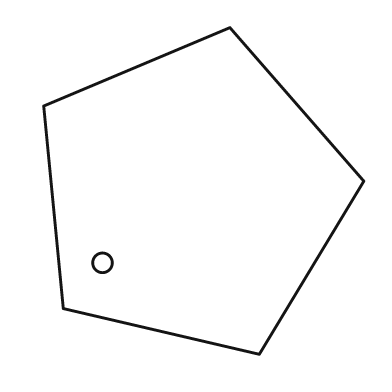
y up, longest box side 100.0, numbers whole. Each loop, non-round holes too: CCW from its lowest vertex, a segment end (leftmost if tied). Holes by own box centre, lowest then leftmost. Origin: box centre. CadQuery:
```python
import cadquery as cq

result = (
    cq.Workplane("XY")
    .moveTo(17.0, -50.0)
    .lineTo(49.0, 3.0)
    .lineTo(8.0, 50.0)
    .lineTo(-49.0, 26.0)
    .lineTo(-43.0, -36.0)
    .close()
    .moveTo(-31.0, -22.0)
    .circle(3.0)
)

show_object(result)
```